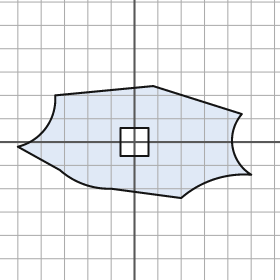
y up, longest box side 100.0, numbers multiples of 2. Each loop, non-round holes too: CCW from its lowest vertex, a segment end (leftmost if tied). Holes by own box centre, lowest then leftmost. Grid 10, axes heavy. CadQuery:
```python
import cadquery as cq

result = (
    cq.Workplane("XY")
    .moveTo(20.0, -24.0)
    .threePointArc((34.0, -16.0), (50.0, -14.0))
    .threePointArc((42.0, -2.0), (46.0, 12.0))
    .lineTo(8.0, 24.0)
    .lineTo(-34.0, 20.0)
    .threePointArc((-38.0, 6.0), (-50.0, -2.0))
    .lineTo(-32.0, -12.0)
    .threePointArc((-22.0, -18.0), (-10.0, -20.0))
    .close()
    .moveTo(-6.0, -6.0)
    .lineTo(6.0, -6.0)
    .lineTo(6.0, 6.0)
    .lineTo(-6.0, 6.0)
    .close()
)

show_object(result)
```